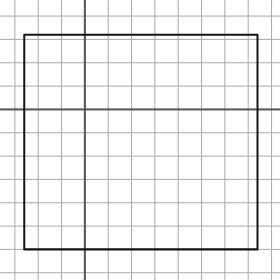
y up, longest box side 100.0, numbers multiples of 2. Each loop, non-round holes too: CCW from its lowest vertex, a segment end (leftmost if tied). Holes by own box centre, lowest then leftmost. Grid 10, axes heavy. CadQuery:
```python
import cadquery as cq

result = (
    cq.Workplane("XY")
    .moveTo(-26.0, -60.0)
    .lineTo(74.0, -60.0)
    .lineTo(74.0, 32.0)
    .lineTo(-26.0, 32.0)
    .close()
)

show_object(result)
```